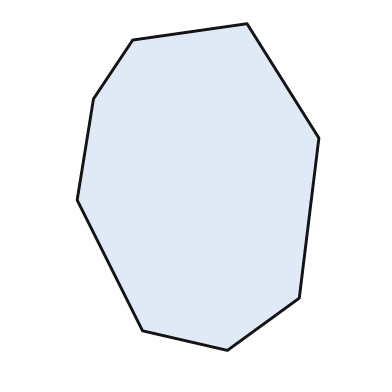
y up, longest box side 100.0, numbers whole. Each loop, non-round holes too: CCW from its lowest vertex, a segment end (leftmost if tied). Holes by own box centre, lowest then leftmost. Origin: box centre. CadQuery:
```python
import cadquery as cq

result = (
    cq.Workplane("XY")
    .moveTo(9.0, -50.0)
    .lineTo(31.0, -34.0)
    .lineTo(37.0, 15.0)
    .lineTo(15.0, 50.0)
    .lineTo(-20.0, 45.0)
    .lineTo(-32.0, 27.0)
    .lineTo(-37.0, -4.0)
    .lineTo(-17.0, -44.0)
    .close()
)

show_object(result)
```